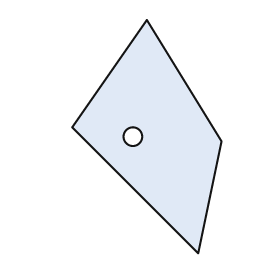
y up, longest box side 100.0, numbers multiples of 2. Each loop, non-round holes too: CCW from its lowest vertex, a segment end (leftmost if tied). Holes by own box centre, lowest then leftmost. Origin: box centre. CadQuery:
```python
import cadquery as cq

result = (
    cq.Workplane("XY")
    .moveTo(22.0, -50.0)
    .lineTo(32.0, -2.0)
    .lineTo(0.0, 50.0)
    .lineTo(-32.0, 4.0)
    .close()
    .moveTo(-6.0, 0.0)
    .circle(4.0)
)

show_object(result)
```